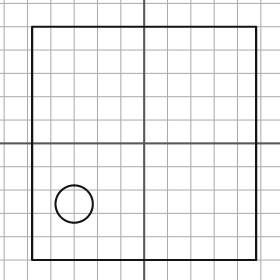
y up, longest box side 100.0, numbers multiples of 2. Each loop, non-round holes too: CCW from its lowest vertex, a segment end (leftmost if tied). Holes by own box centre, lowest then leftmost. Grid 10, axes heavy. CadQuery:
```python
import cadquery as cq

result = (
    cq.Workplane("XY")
    .moveTo(-48.0, -50.0)
    .lineTo(48.0, -50.0)
    .lineTo(48.0, 50.0)
    .lineTo(-48.0, 50.0)
    .close()
    .moveTo(-30.0, -26.0)
    .circle(8.0)
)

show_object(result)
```